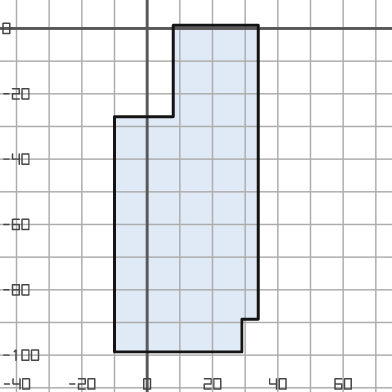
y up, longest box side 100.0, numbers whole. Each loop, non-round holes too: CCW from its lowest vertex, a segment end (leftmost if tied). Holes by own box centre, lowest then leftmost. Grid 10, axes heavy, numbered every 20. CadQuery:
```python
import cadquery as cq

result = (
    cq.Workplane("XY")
    .moveTo(-10.0, -99.0)
    .lineTo(29.0, -99.0)
    .lineTo(29.0, -89.0)
    .lineTo(34.0, -89.0)
    .lineTo(34.0, 1.0)
    .lineTo(8.0, 1.0)
    .lineTo(8.0, -27.0)
    .lineTo(-10.0, -27.0)
    .close()
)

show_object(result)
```